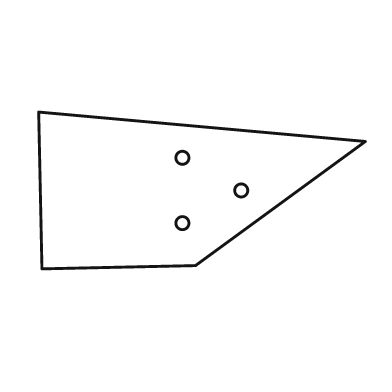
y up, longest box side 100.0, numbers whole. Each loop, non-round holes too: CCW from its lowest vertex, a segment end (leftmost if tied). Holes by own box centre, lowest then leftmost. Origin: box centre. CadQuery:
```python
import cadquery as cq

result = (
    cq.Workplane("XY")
    .moveTo(-49.0, -24.0)
    .lineTo(-2.0, -23.0)
    .lineTo(50.0, 15.0)
    .lineTo(-50.0, 24.0)
    .close()
    .moveTo(-6.0, -10.0)
    .circle(2.0)
    .moveTo(12.0, 0.0)
    .circle(2.0)
    .moveTo(-6.0, 10.0)
    .circle(2.0)
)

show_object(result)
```